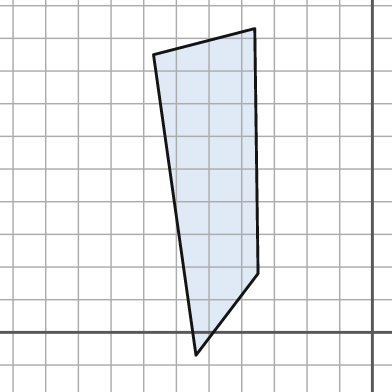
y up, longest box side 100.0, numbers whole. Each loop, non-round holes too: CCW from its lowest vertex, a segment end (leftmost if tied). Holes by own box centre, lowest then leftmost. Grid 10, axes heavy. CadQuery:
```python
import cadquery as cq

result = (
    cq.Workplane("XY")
    .moveTo(-54.0, -7.0)
    .lineTo(-35.0, 18.0)
    .lineTo(-36.0, 93.0)
    .lineTo(-67.0, 85.0)
    .close()
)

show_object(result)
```